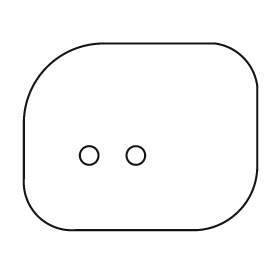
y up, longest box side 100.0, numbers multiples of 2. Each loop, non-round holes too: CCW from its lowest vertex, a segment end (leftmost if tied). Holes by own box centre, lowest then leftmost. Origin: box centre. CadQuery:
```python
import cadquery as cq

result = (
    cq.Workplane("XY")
    .moveTo(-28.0, -40.0)
    .lineTo(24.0, -40.0)
    .threePointArc((42.0, -32.0), (50.0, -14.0))
    .lineTo(50.0, 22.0)
    .threePointArc((44.0, 34.0), (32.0, 40.0))
    .lineTo(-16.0, 40.0)
    .threePointArc((-40.0, 30.0), (-50.0, 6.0))
    .lineTo(-50.0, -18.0)
    .threePointArc((-44.0, -34.0), (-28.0, -40.0))
    .close()
    .moveTo(-22.0, -8.0)
    .circle(4.0)
    .moveTo(-2.0, -8.0)
    .circle(4.0)
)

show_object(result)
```